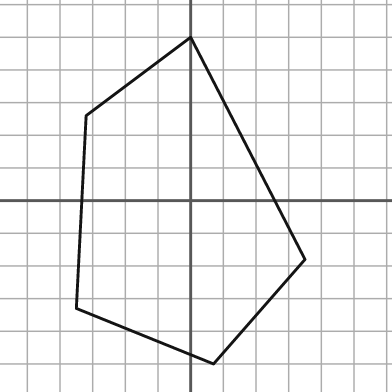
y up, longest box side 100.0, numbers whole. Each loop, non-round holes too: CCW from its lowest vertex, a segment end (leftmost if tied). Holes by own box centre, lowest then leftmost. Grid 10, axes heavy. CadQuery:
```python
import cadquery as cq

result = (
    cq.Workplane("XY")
    .moveTo(7.0, -50.0)
    .lineTo(35.0, -18.0)
    .lineTo(0.0, 50.0)
    .lineTo(-32.0, 26.0)
    .lineTo(-35.0, -33.0)
    .close()
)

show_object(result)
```